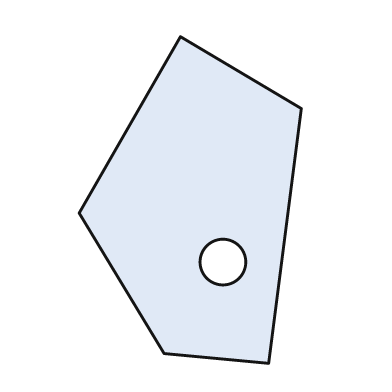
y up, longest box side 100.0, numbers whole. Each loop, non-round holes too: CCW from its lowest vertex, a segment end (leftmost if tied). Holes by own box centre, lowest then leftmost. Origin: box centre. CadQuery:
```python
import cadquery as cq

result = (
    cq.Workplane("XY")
    .moveTo(24.0, -50.0)
    .lineTo(34.0, 28.0)
    .lineTo(-3.0, 50.0)
    .lineTo(-34.0, -4.0)
    .lineTo(-8.0, -47.0)
    .close()
    .moveTo(10.0, -19.0)
    .circle(7.0)
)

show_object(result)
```